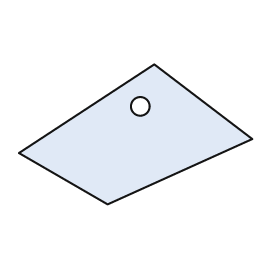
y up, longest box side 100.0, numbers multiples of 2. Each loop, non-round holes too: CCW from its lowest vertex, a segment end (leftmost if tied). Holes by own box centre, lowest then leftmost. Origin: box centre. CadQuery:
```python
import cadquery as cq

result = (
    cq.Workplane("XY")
    .moveTo(-12.0, -30.0)
    .lineTo(50.0, -2.0)
    .lineTo(8.0, 30.0)
    .lineTo(-50.0, -8.0)
    .close()
    .moveTo(2.0, 12.0)
    .circle(4.0)
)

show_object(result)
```